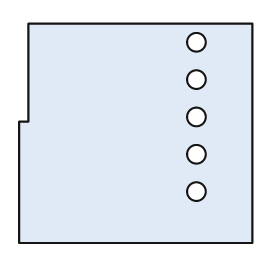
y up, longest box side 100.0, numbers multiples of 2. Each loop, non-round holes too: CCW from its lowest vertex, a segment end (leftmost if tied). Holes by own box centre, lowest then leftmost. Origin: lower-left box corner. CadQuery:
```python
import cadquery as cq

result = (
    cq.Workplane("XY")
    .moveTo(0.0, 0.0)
    .lineTo(100.0, 0.0)
    .lineTo(100.0, 94.0)
    .lineTo(4.0, 94.0)
    .lineTo(4.0, 52.0)
    .lineTo(0.0, 52.0)
    .close()
    .moveTo(76.0, 22.0)
    .circle(4.0)
    .moveTo(76.0, 38.0)
    .circle(4.0)
    .moveTo(76.0, 54.0)
    .circle(4.0)
    .moveTo(76.0, 70.0)
    .circle(4.0)
    .moveTo(76.0, 86.0)
    .circle(4.0)
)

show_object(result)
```